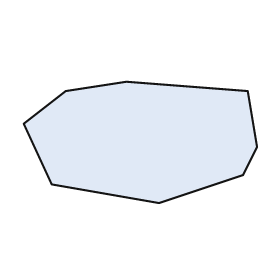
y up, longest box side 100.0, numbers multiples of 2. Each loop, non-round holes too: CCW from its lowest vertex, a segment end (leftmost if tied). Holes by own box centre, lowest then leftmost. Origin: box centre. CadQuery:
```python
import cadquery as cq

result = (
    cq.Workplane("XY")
    .moveTo(8.0, -26.0)
    .lineTo(44.0, -14.0)
    .lineTo(50.0, -2.0)
    .lineTo(46.0, 22.0)
    .lineTo(-6.0, 26.0)
    .lineTo(-32.0, 22.0)
    .lineTo(-50.0, 8.0)
    .lineTo(-38.0, -18.0)
    .close()
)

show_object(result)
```